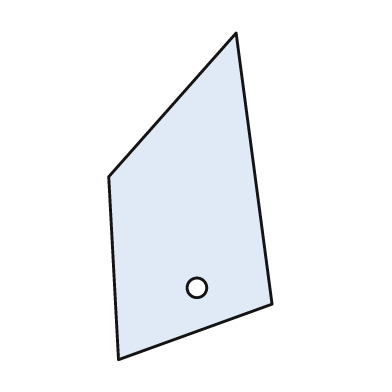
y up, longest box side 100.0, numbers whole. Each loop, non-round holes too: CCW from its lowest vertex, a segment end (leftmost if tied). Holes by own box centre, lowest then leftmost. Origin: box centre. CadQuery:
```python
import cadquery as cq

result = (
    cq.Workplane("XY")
    .moveTo(-22.0, -50.0)
    .lineTo(25.0, -33.0)
    .lineTo(14.0, 50.0)
    .lineTo(-25.0, 6.0)
    .close()
    .moveTo(2.0, -28.0)
    .circle(3.0)
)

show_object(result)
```